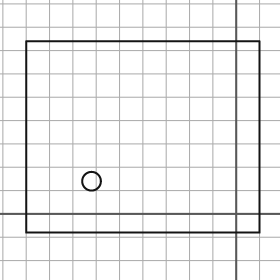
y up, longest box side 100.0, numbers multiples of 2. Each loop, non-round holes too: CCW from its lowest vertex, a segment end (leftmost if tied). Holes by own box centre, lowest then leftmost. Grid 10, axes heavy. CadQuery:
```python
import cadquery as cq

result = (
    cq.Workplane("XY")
    .moveTo(-90.0, -8.0)
    .lineTo(10.0, -8.0)
    .lineTo(10.0, 74.0)
    .lineTo(-90.0, 74.0)
    .close()
    .moveTo(-62.0, 14.0)
    .circle(4.0)
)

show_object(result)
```